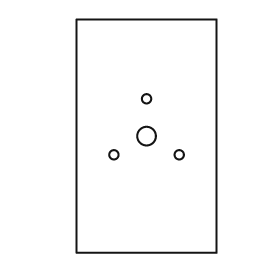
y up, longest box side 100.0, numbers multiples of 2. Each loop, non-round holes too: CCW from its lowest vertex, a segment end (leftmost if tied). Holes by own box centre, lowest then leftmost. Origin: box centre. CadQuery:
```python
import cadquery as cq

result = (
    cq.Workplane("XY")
    .moveTo(-30.0, -50.0)
    .lineTo(30.0, -50.0)
    .lineTo(30.0, 50.0)
    .lineTo(-30.0, 50.0)
    .close()
    .moveTo(-14.0, -8.0)
    .circle(2.0)
    .moveTo(14.0, -8.0)
    .circle(2.0)
    .moveTo(0.0, 0.0)
    .circle(4.0)
    .moveTo(0.0, 16.0)
    .circle(2.0)
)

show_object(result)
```